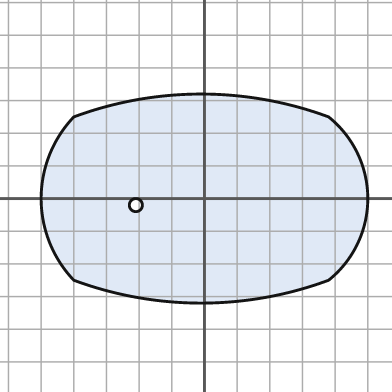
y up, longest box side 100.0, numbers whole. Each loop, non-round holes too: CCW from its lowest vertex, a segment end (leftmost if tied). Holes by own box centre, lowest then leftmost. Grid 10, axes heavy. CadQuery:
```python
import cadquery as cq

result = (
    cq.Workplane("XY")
    .moveTo(-40.0, -25.0)
    .threePointArc((-1.0, -32.0), (38.0, -25.0))
    .threePointArc((50.0, 0.0), (38.0, 25.0))
    .threePointArc((-1.0, 32.0), (-40.0, 25.0))
    .threePointArc((-50.0, 0.0), (-40.0, -25.0))
    .close()
    .moveTo(-21.0, -2.0)
    .circle(2.0)
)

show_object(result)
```